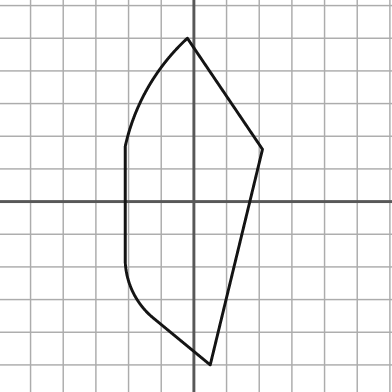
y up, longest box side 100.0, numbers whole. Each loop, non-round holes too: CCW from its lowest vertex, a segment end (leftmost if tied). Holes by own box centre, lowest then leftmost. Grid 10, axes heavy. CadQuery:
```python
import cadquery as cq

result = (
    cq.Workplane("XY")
    .moveTo(5.0, -50.0)
    .lineTo(21.0, 16.0)
    .lineTo(-2.0, 50.0)
    .threePointArc((-14.0, 35.0), (-21.0, 17.0))
    .lineTo(-21.0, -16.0)
    .threePointArc((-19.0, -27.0), (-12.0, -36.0))
    .close()
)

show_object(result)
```